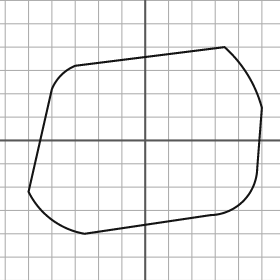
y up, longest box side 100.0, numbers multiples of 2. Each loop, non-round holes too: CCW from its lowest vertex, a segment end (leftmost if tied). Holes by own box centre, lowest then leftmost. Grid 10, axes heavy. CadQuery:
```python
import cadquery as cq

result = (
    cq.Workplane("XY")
    .moveTo(-26.0, -40.0)
    .lineTo(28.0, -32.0)
    .threePointArc((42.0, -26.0), (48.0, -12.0))
    .lineTo(50.0, 14.0)
    .threePointArc((44.0, 28.0), (34.0, 40.0))
    .lineTo(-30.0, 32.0)
    .threePointArc((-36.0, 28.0), (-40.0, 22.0))
    .lineTo(-50.0, -22.0)
    .threePointArc((-40.0, -34.0), (-26.0, -40.0))
    .close()
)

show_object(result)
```